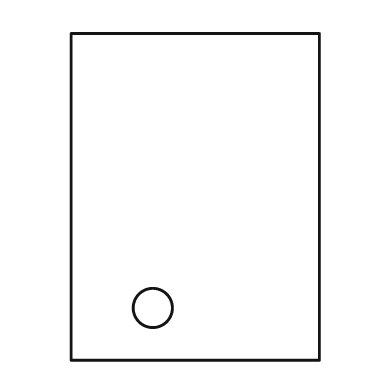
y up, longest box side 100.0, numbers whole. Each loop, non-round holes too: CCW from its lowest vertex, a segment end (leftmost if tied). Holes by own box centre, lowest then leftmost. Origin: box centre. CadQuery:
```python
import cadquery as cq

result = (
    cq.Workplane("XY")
    .moveTo(-38.0, -50.0)
    .lineTo(38.0, -50.0)
    .lineTo(38.0, 50.0)
    .lineTo(-38.0, 50.0)
    .close()
    .moveTo(-13.0, -34.0)
    .circle(6.0)
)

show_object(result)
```